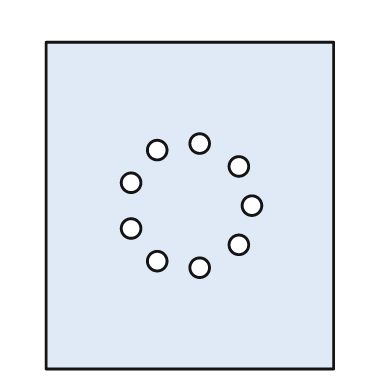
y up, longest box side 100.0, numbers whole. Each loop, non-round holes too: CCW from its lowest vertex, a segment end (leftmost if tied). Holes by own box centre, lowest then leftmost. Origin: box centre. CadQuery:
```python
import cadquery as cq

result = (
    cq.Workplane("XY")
    .moveTo(-44.0, -50.0)
    .lineTo(44.0, -50.0)
    .lineTo(44.0, 50.0)
    .lineTo(-44.0, 50.0)
    .close()
    .moveTo(3.0, -19.0)
    .circle(3.0)
    .moveTo(-10.0, -17.0)
    .circle(3.0)
    .moveTo(15.0, -12.0)
    .circle(3.0)
    .moveTo(-18.0, -7.0)
    .circle(3.0)
    .moveTo(19.0, 0.0)
    .circle(3.0)
    .moveTo(-18.0, 7.0)
    .circle(3.0)
    .moveTo(15.0, 12.0)
    .circle(3.0)
    .moveTo(-10.0, 17.0)
    .circle(3.0)
    .moveTo(3.0, 19.0)
    .circle(3.0)
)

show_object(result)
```